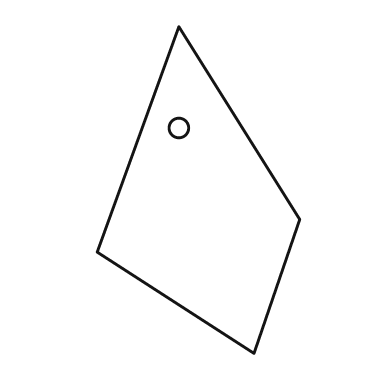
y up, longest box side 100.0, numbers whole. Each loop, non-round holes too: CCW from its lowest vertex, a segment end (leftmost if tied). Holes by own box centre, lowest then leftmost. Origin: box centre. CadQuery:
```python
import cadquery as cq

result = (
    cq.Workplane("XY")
    .moveTo(17.0, -50.0)
    .lineTo(31.0, -9.0)
    .lineTo(-6.0, 50.0)
    .lineTo(-31.0, -19.0)
    .close()
    .moveTo(-6.0, 19.0)
    .circle(3.0)
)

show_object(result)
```